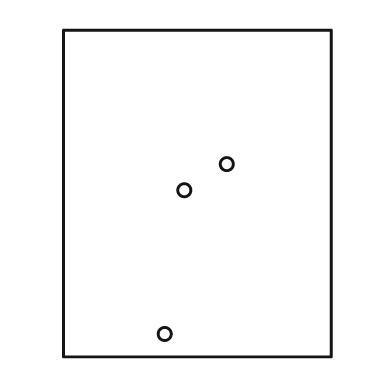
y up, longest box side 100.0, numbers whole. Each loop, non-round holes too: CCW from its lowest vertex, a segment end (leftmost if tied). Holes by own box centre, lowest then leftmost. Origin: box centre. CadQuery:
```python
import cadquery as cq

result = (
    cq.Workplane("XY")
    .moveTo(-41.0, -50.0)
    .lineTo(41.0, -50.0)
    .lineTo(41.0, 50.0)
    .lineTo(-41.0, 50.0)
    .close()
    .moveTo(-10.0, -43.0)
    .circle(2.0)
    .moveTo(-4.0, 1.0)
    .circle(2.0)
    .moveTo(9.0, 9.0)
    .circle(2.0)
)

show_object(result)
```